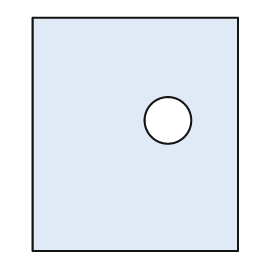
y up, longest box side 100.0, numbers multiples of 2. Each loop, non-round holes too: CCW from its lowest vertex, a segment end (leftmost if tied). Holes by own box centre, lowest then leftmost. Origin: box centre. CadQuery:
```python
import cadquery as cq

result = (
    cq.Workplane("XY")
    .moveTo(-44.0, -50.0)
    .lineTo(44.0, -50.0)
    .lineTo(44.0, 50.0)
    .lineTo(-44.0, 50.0)
    .close()
    .moveTo(14.0, 6.0)
    .circle(10.0)
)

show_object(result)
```